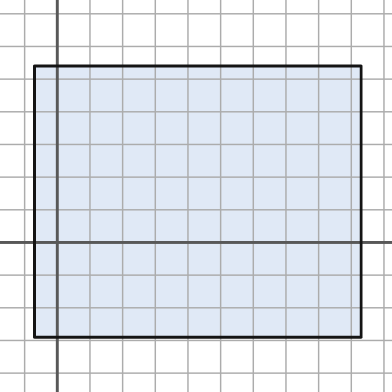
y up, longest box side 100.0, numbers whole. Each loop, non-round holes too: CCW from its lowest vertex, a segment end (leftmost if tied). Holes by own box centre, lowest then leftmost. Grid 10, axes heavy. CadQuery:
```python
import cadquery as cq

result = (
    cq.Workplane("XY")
    .moveTo(-7.0, -29.0)
    .lineTo(93.0, -29.0)
    .lineTo(93.0, 54.0)
    .lineTo(-7.0, 54.0)
    .close()
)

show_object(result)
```